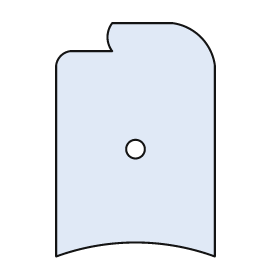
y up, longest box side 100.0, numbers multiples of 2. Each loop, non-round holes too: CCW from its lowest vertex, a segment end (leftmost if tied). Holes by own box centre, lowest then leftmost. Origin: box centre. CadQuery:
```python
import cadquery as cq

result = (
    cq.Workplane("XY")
    .moveTo(-34.0, -50.0)
    .threePointArc((0.0, -44.0), (34.0, -50.0))
    .lineTo(34.0, 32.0)
    .threePointArc((28.0, 44.0), (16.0, 50.0))
    .lineTo(-10.0, 50.0)
    .threePointArc((-12.0, 44.0), (-10.0, 38.0))
    .lineTo(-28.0, 38.0)
    .threePointArc((-32.0, 36.0), (-34.0, 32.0))
    .close()
    .moveTo(0.0, -4.0)
    .circle(4.0)
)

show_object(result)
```